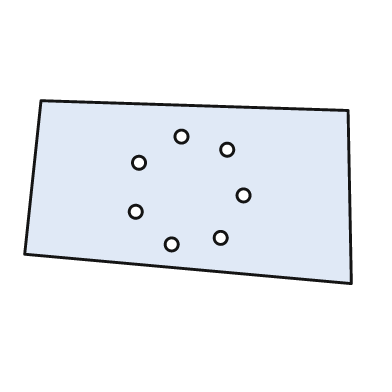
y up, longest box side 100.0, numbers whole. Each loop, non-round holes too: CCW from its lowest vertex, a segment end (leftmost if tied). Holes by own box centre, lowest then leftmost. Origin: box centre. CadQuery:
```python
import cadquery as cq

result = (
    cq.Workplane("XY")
    .moveTo(50.0, -28.0)
    .lineTo(49.0, 25.0)
    .lineTo(-45.0, 28.0)
    .lineTo(-50.0, -19.0)
    .close()
    .moveTo(-5.0, -16.0)
    .circle(2.0)
    .moveTo(10.0, -14.0)
    .circle(2.0)
    .moveTo(-16.0, -6.0)
    .circle(2.0)
    .moveTo(17.0, -1.0)
    .circle(2.0)
    .moveTo(-15.0, 9.0)
    .circle(2.0)
    .moveTo(12.0, 13.0)
    .circle(2.0)
    .moveTo(-2.0, 17.0)
    .circle(2.0)
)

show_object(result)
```